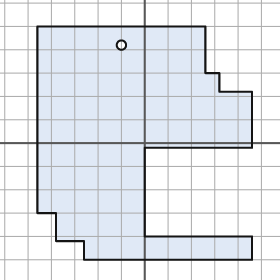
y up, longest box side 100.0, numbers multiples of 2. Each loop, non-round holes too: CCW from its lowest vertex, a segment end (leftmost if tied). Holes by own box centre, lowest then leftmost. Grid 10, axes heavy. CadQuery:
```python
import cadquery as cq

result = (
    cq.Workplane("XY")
    .moveTo(-26.0, -50.0)
    .lineTo(46.0, -50.0)
    .lineTo(46.0, -40.0)
    .lineTo(0.0, -40.0)
    .lineTo(0.0, -2.0)
    .lineTo(46.0, -2.0)
    .lineTo(46.0, 22.0)
    .lineTo(32.0, 22.0)
    .lineTo(32.0, 30.0)
    .lineTo(26.0, 30.0)
    .lineTo(26.0, 50.0)
    .lineTo(-46.0, 50.0)
    .lineTo(-46.0, -30.0)
    .lineTo(-38.0, -30.0)
    .lineTo(-38.0, -42.0)
    .lineTo(-26.0, -42.0)
    .close()
    .moveTo(-10.0, 42.0)
    .circle(2.0)
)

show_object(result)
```